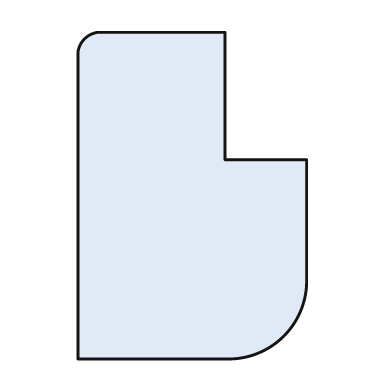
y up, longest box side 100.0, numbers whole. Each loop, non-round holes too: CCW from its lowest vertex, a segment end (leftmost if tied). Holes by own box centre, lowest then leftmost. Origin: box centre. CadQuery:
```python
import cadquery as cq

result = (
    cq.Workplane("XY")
    .moveTo(-35.0, -50.0)
    .lineTo(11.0, -50.0)
    .threePointArc((28.0, -43.0), (35.0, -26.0))
    .lineTo(35.0, 11.0)
    .lineTo(10.0, 11.0)
    .lineTo(10.0, 50.0)
    .lineTo(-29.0, 50.0)
    .threePointArc((-33.0, 48.0), (-35.0, 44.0))
    .close()
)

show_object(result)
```